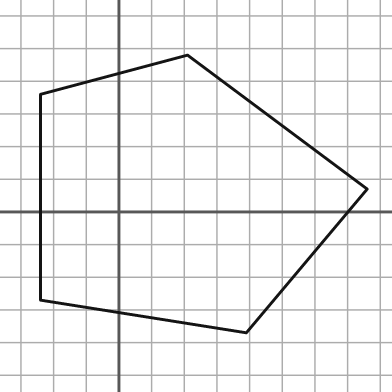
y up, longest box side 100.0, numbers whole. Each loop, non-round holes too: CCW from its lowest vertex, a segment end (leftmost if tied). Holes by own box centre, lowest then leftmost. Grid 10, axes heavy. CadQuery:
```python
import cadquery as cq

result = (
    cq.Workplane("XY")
    .moveTo(39.0, -37.0)
    .lineTo(76.0, 7.0)
    .lineTo(21.0, 48.0)
    .lineTo(-24.0, 36.0)
    .lineTo(-24.0, -27.0)
    .close()
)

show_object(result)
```